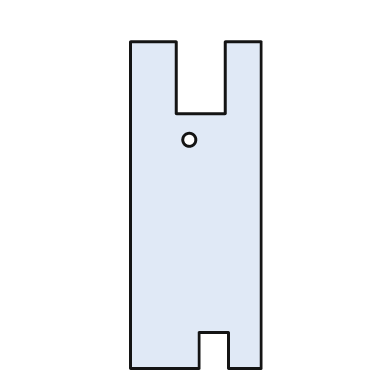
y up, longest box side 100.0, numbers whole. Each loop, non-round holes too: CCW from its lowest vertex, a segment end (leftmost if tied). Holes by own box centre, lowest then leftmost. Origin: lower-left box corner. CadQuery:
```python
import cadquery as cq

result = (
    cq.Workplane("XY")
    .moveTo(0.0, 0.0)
    .lineTo(21.0, 0.0)
    .lineTo(21.0, 11.0)
    .lineTo(30.0, 11.0)
    .lineTo(30.0, 0.0)
    .lineTo(40.0, 0.0)
    .lineTo(40.0, 100.0)
    .lineTo(29.0, 100.0)
    .lineTo(29.0, 78.0)
    .lineTo(14.0, 78.0)
    .lineTo(14.0, 100.0)
    .lineTo(0.0, 100.0)
    .close()
    .moveTo(18.0, 70.0)
    .circle(2.0)
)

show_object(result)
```